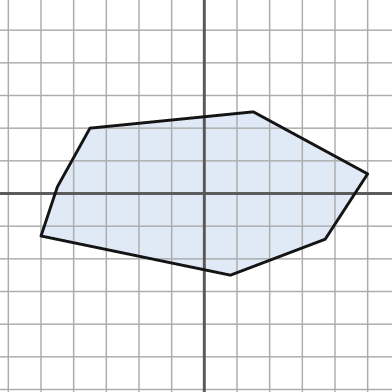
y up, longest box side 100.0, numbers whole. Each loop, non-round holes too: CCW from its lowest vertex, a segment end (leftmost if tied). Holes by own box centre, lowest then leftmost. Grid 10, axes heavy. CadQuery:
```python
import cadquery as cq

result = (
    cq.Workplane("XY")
    .moveTo(8.0, -25.0)
    .lineTo(37.0, -14.0)
    .lineTo(50.0, 6.0)
    .lineTo(15.0, 25.0)
    .lineTo(-35.0, 20.0)
    .lineTo(-45.0, 2.0)
    .lineTo(-50.0, -13.0)
    .close()
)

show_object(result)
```